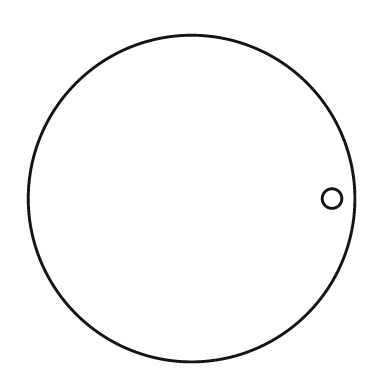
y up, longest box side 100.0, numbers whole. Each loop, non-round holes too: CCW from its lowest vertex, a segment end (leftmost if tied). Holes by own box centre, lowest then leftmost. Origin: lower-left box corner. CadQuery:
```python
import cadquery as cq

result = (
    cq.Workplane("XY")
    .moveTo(50.0, 50.0)
    .circle(50.0)
    .moveTo(93.0, 50.0)
    .circle(3.0)
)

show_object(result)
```